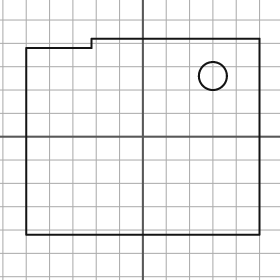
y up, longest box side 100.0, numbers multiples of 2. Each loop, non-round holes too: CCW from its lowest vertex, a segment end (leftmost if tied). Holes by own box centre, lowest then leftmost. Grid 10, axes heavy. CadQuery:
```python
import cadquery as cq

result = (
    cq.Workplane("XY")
    .moveTo(-50.0, -42.0)
    .lineTo(50.0, -42.0)
    .lineTo(50.0, 42.0)
    .lineTo(-22.0, 42.0)
    .lineTo(-22.0, 38.0)
    .lineTo(-50.0, 38.0)
    .close()
    .moveTo(30.0, 26.0)
    .circle(6.0)
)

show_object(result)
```